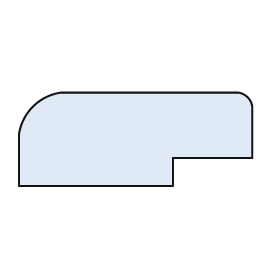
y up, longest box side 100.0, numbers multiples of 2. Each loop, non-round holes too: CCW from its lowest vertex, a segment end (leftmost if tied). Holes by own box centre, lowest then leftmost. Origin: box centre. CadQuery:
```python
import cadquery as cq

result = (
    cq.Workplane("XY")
    .moveTo(-50.0, -20.0)
    .lineTo(16.0, -20.0)
    .lineTo(16.0, -8.0)
    .lineTo(50.0, -8.0)
    .lineTo(50.0, 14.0)
    .threePointArc((48.0, 18.0), (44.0, 20.0))
    .lineTo(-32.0, 20.0)
    .threePointArc((-44.0, 14.0), (-50.0, 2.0))
    .close()
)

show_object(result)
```